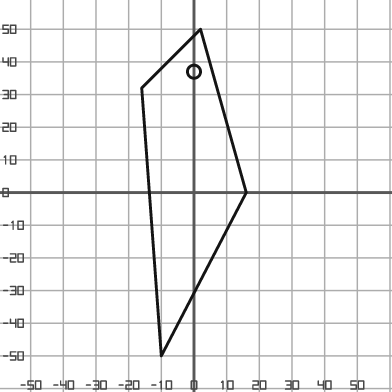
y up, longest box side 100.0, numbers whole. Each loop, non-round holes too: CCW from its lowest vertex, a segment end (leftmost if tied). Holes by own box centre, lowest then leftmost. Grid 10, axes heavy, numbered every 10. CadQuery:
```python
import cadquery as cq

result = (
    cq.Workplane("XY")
    .moveTo(-10.0, -50.0)
    .lineTo(16.0, 0.0)
    .lineTo(2.0, 50.0)
    .lineTo(-16.0, 32.0)
    .close()
    .moveTo(0.0, 37.0)
    .circle(2.0)
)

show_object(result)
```